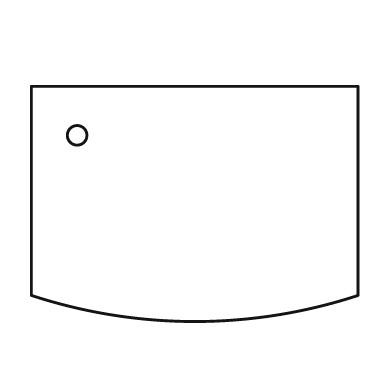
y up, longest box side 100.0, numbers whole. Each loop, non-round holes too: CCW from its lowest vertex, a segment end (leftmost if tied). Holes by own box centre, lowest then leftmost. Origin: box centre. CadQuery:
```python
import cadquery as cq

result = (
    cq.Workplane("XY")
    .moveTo(-50.0, -28.0)
    .threePointArc((0.0, -36.0), (50.0, -28.0))
    .lineTo(50.0, 36.0)
    .lineTo(-50.0, 36.0)
    .close()
    .moveTo(-36.0, 21.0)
    .circle(3.0)
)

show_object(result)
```